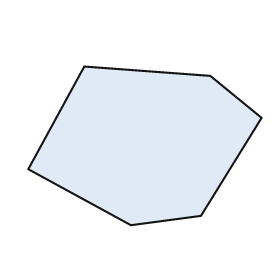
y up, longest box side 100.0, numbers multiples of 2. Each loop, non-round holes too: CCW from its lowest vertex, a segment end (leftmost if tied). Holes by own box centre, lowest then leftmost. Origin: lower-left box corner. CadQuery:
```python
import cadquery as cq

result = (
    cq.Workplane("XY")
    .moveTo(44.0, 0.0)
    .lineTo(74.0, 4.0)
    .lineTo(100.0, 46.0)
    .lineTo(78.0, 64.0)
    .lineTo(24.0, 68.0)
    .lineTo(0.0, 24.0)
    .close()
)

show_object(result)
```